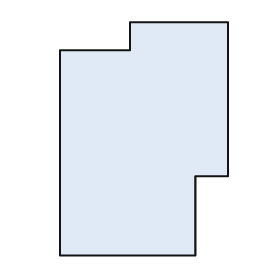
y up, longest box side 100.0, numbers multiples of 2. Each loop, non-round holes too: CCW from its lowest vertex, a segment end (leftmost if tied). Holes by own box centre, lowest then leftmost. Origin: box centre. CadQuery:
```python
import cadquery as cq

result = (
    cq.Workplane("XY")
    .moveTo(-36.0, -50.0)
    .lineTo(22.0, -50.0)
    .lineTo(22.0, -16.0)
    .lineTo(36.0, -16.0)
    .lineTo(36.0, 50.0)
    .lineTo(-6.0, 50.0)
    .lineTo(-6.0, 38.0)
    .lineTo(-36.0, 38.0)
    .close()
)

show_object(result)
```